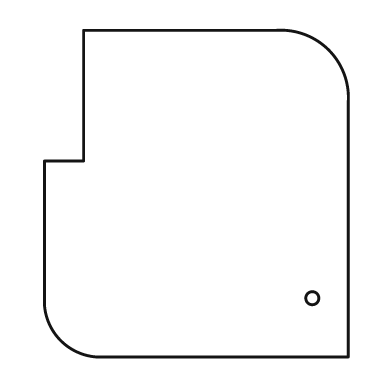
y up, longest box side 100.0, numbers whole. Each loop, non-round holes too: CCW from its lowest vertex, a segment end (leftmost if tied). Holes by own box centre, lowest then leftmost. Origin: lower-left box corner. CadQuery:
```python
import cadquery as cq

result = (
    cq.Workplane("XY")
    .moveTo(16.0, 0.0)
    .lineTo(93.0, 0.0)
    .lineTo(93.0, 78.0)
    .threePointArc((87.0, 94.0), (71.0, 100.0))
    .lineTo(12.0, 100.0)
    .lineTo(12.0, 60.0)
    .lineTo(0.0, 60.0)
    .lineTo(0.0, 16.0)
    .threePointArc((5.0, 5.0), (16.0, 0.0))
    .close()
    .moveTo(82.0, 18.0)
    .circle(2.0)
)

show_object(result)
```